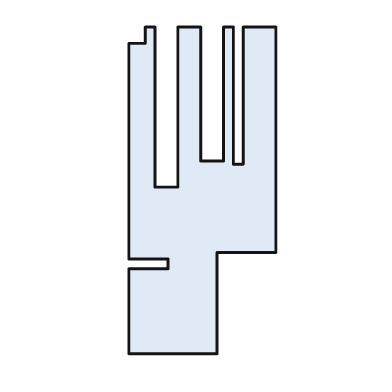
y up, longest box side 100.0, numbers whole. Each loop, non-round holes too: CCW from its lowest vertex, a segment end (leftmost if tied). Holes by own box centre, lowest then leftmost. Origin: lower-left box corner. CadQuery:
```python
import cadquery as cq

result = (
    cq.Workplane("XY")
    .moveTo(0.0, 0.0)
    .lineTo(27.0, 0.0)
    .lineTo(27.0, 31.0)
    .lineTo(45.0, 31.0)
    .lineTo(45.0, 100.0)
    .lineTo(35.0, 100.0)
    .lineTo(35.0, 58.0)
    .lineTo(32.0, 58.0)
    .lineTo(32.0, 100.0)
    .lineTo(29.0, 100.0)
    .lineTo(29.0, 59.0)
    .lineTo(22.0, 59.0)
    .lineTo(22.0, 100.0)
    .lineTo(15.0, 100.0)
    .lineTo(15.0, 51.0)
    .lineTo(8.0, 51.0)
    .lineTo(8.0, 100.0)
    .lineTo(5.0, 100.0)
    .lineTo(5.0, 95.0)
    .lineTo(0.0, 95.0)
    .lineTo(0.0, 29.0)
    .lineTo(12.0, 29.0)
    .lineTo(12.0, 26.0)
    .lineTo(0.0, 26.0)
    .close()
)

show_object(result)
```